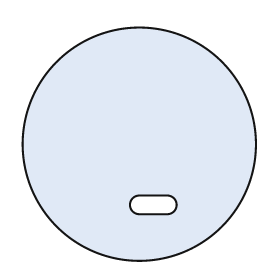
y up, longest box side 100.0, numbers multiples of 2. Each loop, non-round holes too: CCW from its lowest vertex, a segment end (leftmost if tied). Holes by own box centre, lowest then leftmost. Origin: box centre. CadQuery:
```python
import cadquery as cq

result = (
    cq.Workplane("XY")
    .moveTo(0.0, 0.0)
    .circle(50.0)
    .moveTo(0.0, -30.0)
    .lineTo(12.0, -30.0)
    .threePointArc((16.0, -26.0), (12.0, -22.0))
    .lineTo(0.0, -22.0)
    .threePointArc((-4.0, -26.0), (0.0, -30.0))
    .close()
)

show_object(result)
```